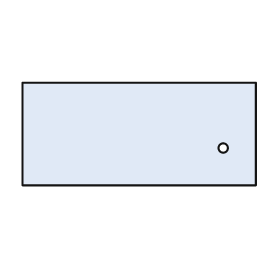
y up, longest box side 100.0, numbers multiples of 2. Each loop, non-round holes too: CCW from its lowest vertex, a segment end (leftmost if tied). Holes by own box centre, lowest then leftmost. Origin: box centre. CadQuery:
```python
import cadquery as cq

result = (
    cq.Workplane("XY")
    .moveTo(-50.0, -22.0)
    .lineTo(50.0, -22.0)
    .lineTo(50.0, 22.0)
    .lineTo(-50.0, 22.0)
    .close()
    .moveTo(36.0, -6.0)
    .circle(2.0)
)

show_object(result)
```